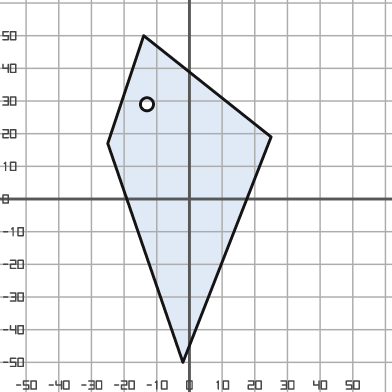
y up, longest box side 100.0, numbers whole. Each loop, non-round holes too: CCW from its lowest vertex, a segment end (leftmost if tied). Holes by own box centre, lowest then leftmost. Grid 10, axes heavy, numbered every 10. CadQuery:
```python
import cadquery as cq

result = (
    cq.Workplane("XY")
    .moveTo(-2.0, -50.0)
    .lineTo(25.0, 19.0)
    .lineTo(-14.0, 50.0)
    .lineTo(-25.0, 17.0)
    .close()
    .moveTo(-13.0, 29.0)
    .circle(2.0)
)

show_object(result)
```